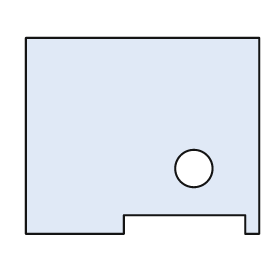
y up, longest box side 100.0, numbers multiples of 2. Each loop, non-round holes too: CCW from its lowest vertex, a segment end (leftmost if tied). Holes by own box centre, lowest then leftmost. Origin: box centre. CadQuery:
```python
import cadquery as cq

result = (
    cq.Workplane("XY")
    .moveTo(-50.0, -42.0)
    .lineTo(-8.0, -42.0)
    .lineTo(-8.0, -34.0)
    .lineTo(44.0, -34.0)
    .lineTo(44.0, -42.0)
    .lineTo(50.0, -42.0)
    .lineTo(50.0, 42.0)
    .lineTo(-50.0, 42.0)
    .close()
    .moveTo(22.0, -14.0)
    .circle(8.0)
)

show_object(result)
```